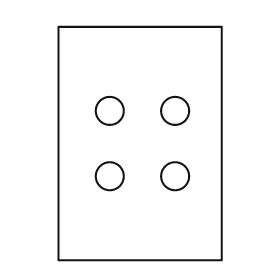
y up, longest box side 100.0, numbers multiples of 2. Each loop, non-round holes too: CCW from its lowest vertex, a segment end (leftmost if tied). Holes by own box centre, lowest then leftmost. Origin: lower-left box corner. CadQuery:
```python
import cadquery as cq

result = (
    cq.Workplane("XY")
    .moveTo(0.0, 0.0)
    .lineTo(70.0, 0.0)
    .lineTo(70.0, 100.0)
    .lineTo(0.0, 100.0)
    .close()
    .moveTo(22.0, 36.0)
    .circle(6.0)
    .moveTo(50.0, 36.0)
    .circle(6.0)
    .moveTo(22.0, 64.0)
    .circle(6.0)
    .moveTo(50.0, 64.0)
    .circle(6.0)
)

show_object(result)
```